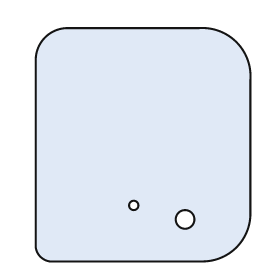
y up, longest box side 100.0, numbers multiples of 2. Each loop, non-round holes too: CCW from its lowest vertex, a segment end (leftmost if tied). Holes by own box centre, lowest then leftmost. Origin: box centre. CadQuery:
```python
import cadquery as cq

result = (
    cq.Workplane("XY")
    .moveTo(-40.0, -50.0)
    .lineTo(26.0, -50.0)
    .threePointArc((40.0, -44.0), (46.0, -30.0))
    .lineTo(46.0, 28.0)
    .threePointArc((40.0, 44.0), (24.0, 50.0))
    .lineTo(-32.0, 50.0)
    .threePointArc((-42.0, 46.0), (-46.0, 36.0))
    .lineTo(-46.0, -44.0)
    .threePointArc((-44.0, -48.0), (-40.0, -50.0))
    .close()
    .moveTo(18.0, -32.0)
    .circle(4.0)
    .moveTo(-4.0, -26.0)
    .circle(2.0)
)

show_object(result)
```